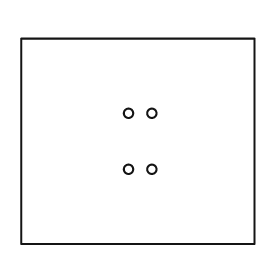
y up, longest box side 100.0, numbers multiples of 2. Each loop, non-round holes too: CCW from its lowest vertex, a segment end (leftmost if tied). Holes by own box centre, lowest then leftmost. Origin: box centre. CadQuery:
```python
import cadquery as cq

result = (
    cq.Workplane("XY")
    .moveTo(-50.0, -44.0)
    .lineTo(50.0, -44.0)
    .lineTo(50.0, 44.0)
    .lineTo(-50.0, 44.0)
    .close()
    .moveTo(-4.0, -12.0)
    .circle(2.0)
    .moveTo(6.0, -12.0)
    .circle(2.0)
    .moveTo(-4.0, 12.0)
    .circle(2.0)
    .moveTo(6.0, 12.0)
    .circle(2.0)
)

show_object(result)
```